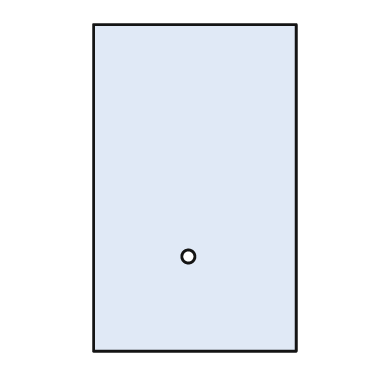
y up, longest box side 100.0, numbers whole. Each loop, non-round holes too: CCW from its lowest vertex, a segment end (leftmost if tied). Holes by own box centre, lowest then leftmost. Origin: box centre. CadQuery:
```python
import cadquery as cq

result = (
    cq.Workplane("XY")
    .moveTo(-31.0, -50.0)
    .lineTo(31.0, -50.0)
    .lineTo(31.0, 50.0)
    .lineTo(-31.0, 50.0)
    .close()
    .moveTo(-2.0, -21.0)
    .circle(2.0)
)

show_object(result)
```